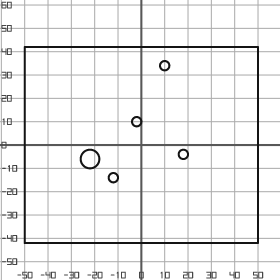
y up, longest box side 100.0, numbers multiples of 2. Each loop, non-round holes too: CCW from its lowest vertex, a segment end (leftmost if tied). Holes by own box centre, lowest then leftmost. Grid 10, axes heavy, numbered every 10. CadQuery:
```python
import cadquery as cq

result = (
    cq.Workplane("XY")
    .moveTo(-50.0, -42.0)
    .lineTo(50.0, -42.0)
    .lineTo(50.0, 42.0)
    .lineTo(-50.0, 42.0)
    .close()
    .moveTo(-12.0, -14.0)
    .circle(2.0)
    .moveTo(-22.0, -6.0)
    .circle(4.0)
    .moveTo(18.0, -4.0)
    .circle(2.0)
    .moveTo(-2.0, 10.0)
    .circle(2.0)
    .moveTo(10.0, 34.0)
    .circle(2.0)
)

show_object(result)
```